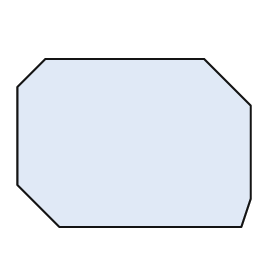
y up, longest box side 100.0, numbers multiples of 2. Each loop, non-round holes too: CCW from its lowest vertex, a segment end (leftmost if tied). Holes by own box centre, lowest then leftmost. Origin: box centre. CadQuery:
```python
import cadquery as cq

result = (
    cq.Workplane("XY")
    .moveTo(-32.0, -36.0)
    .lineTo(46.0, -36.0)
    .lineTo(50.0, -24.0)
    .lineTo(50.0, 16.0)
    .lineTo(30.0, 36.0)
    .lineTo(-38.0, 36.0)
    .lineTo(-50.0, 24.0)
    .lineTo(-50.0, -18.0)
    .close()
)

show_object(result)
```